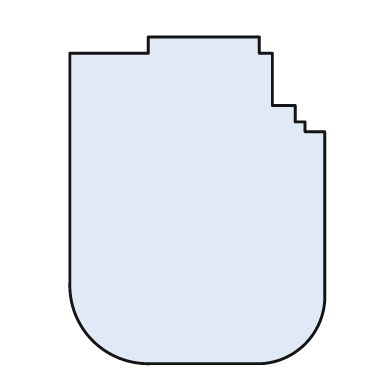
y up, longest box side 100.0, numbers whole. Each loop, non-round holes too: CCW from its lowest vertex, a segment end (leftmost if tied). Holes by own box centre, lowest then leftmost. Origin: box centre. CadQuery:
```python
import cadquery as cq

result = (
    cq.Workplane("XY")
    .moveTo(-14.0, -50.0)
    .lineTo(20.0, -50.0)
    .threePointArc((33.0, -44.0), (39.0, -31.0))
    .lineTo(39.0, 21.0)
    .lineTo(33.0, 21.0)
    .lineTo(33.0, 24.0)
    .lineTo(30.0, 24.0)
    .lineTo(30.0, 29.0)
    .lineTo(23.0, 29.0)
    .lineTo(23.0, 45.0)
    .lineTo(19.0, 45.0)
    .lineTo(19.0, 50.0)
    .lineTo(-15.0, 50.0)
    .lineTo(-15.0, 45.0)
    .lineTo(-39.0, 45.0)
    .lineTo(-39.0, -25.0)
    .threePointArc((-32.0, -43.0), (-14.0, -50.0))
    .close()
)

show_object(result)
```